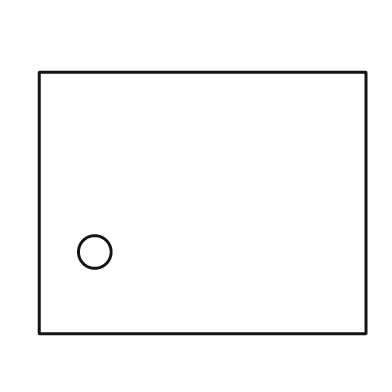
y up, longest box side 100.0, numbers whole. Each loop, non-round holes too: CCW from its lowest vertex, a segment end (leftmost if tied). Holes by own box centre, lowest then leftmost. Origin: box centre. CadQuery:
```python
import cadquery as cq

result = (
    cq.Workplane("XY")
    .moveTo(-50.0, -40.0)
    .lineTo(50.0, -40.0)
    .lineTo(50.0, 40.0)
    .lineTo(-50.0, 40.0)
    .close()
    .moveTo(-33.0, -15.0)
    .circle(5.0)
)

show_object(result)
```